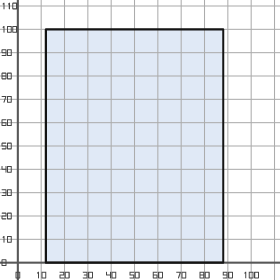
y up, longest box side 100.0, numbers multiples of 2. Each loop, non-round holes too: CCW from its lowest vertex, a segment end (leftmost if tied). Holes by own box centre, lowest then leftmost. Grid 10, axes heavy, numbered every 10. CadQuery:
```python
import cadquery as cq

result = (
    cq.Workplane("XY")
    .moveTo(12.0, 0.0)
    .lineTo(88.0, 0.0)
    .lineTo(88.0, 100.0)
    .lineTo(12.0, 100.0)
    .close()
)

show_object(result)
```